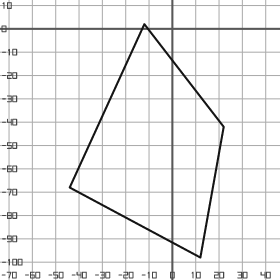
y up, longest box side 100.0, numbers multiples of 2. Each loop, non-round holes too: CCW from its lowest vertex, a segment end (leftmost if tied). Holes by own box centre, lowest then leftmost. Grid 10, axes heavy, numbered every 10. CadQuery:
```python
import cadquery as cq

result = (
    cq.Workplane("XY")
    .moveTo(12.0, -98.0)
    .lineTo(22.0, -42.0)
    .lineTo(-12.0, 2.0)
    .lineTo(-44.0, -68.0)
    .close()
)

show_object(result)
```